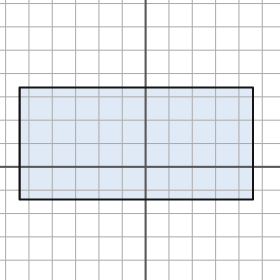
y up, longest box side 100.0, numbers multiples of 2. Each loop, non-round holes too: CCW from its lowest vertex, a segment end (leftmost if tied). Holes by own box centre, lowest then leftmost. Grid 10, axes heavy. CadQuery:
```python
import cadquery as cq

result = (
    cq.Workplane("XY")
    .moveTo(-54.0, -14.0)
    .lineTo(46.0, -14.0)
    .lineTo(46.0, 34.0)
    .lineTo(-54.0, 34.0)
    .close()
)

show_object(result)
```